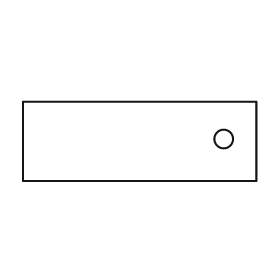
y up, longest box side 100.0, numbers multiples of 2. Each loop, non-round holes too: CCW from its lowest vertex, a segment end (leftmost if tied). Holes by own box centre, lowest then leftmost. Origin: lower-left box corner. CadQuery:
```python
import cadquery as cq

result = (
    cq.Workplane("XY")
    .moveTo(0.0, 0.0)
    .lineTo(100.0, 0.0)
    .lineTo(100.0, 34.0)
    .lineTo(0.0, 34.0)
    .close()
    .moveTo(86.0, 18.0)
    .circle(4.0)
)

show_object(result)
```